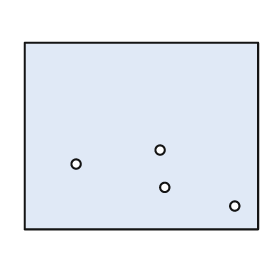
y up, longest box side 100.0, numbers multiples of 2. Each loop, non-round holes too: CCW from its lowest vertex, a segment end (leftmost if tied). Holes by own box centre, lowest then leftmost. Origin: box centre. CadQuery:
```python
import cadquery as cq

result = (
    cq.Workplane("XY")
    .moveTo(-50.0, -40.0)
    .lineTo(50.0, -40.0)
    .lineTo(50.0, 40.0)
    .lineTo(-50.0, 40.0)
    .close()
    .moveTo(40.0, -30.0)
    .circle(2.0)
    .moveTo(10.0, -22.0)
    .circle(2.0)
    .moveTo(-28.0, -12.0)
    .circle(2.0)
    .moveTo(8.0, -6.0)
    .circle(2.0)
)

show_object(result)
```